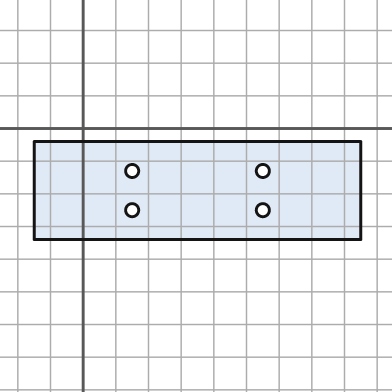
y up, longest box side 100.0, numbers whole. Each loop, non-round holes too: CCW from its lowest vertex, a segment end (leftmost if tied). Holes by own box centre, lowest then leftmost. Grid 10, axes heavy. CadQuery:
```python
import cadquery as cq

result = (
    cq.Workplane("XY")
    .moveTo(-15.0, -34.0)
    .lineTo(85.0, -34.0)
    .lineTo(85.0, -4.0)
    .lineTo(-15.0, -4.0)
    .close()
    .moveTo(15.0, -25.0)
    .circle(2.0)
    .moveTo(55.0, -25.0)
    .circle(2.0)
    .moveTo(15.0, -13.0)
    .circle(2.0)
    .moveTo(55.0, -13.0)
    .circle(2.0)
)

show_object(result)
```